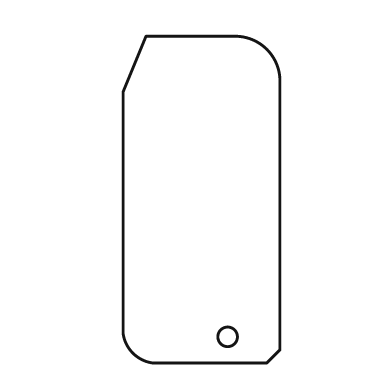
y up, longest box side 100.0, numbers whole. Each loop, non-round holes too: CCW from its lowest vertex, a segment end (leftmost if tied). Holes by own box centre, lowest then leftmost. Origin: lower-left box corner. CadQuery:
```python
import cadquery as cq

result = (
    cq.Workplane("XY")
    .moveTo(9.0, 0.0)
    .lineTo(44.0, 0.0)
    .lineTo(48.0, 4.0)
    .lineTo(48.0, 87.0)
    .threePointArc((44.0, 96.0), (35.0, 100.0))
    .lineTo(7.0, 100.0)
    .lineTo(0.0, 83.0)
    .lineTo(0.0, 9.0)
    .threePointArc((3.0, 3.0), (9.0, 0.0))
    .close()
    .moveTo(32.0, 8.0)
    .circle(3.0)
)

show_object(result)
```